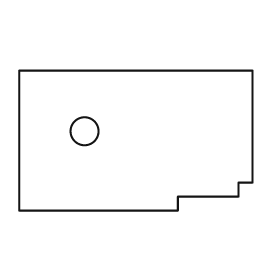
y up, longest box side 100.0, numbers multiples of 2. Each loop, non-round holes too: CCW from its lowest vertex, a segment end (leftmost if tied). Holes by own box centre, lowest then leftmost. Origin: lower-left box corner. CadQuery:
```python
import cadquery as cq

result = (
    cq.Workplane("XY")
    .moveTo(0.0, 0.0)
    .lineTo(68.0, 0.0)
    .lineTo(68.0, 6.0)
    .lineTo(94.0, 6.0)
    .lineTo(94.0, 12.0)
    .lineTo(100.0, 12.0)
    .lineTo(100.0, 60.0)
    .lineTo(0.0, 60.0)
    .close()
    .moveTo(28.0, 34.0)
    .circle(6.0)
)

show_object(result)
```